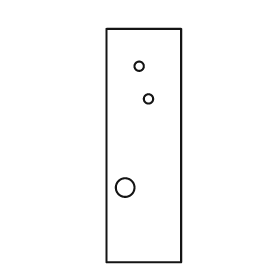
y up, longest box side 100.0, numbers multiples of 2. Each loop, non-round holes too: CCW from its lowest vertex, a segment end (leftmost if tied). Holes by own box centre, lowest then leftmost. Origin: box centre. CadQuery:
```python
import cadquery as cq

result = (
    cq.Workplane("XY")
    .moveTo(-16.0, -50.0)
    .lineTo(16.0, -50.0)
    .lineTo(16.0, 50.0)
    .lineTo(-16.0, 50.0)
    .close()
    .moveTo(-8.0, -18.0)
    .circle(4.0)
    .moveTo(2.0, 20.0)
    .circle(2.0)
    .moveTo(-2.0, 34.0)
    .circle(2.0)
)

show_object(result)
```